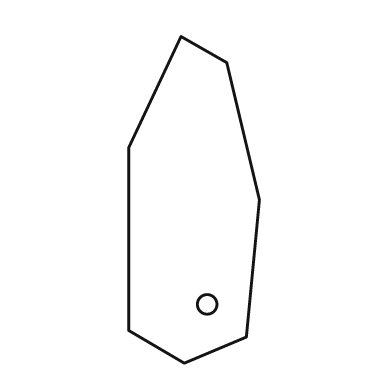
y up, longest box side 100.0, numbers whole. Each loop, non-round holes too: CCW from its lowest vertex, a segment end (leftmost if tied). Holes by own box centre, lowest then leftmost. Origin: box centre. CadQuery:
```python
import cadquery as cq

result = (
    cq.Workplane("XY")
    .moveTo(-3.0, -50.0)
    .lineTo(16.0, -42.0)
    .lineTo(20.0, 0.0)
    .lineTo(10.0, 42.0)
    .lineTo(-4.0, 50.0)
    .lineTo(-20.0, 16.0)
    .lineTo(-20.0, -40.0)
    .close()
    .moveTo(4.0, -32.0)
    .circle(3.0)
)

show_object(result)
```